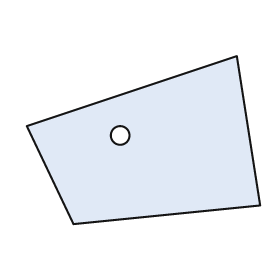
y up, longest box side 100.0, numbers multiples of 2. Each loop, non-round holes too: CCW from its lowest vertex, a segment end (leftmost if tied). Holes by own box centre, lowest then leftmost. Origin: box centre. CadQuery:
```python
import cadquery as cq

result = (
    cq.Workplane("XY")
    .moveTo(-30.0, -36.0)
    .lineTo(50.0, -28.0)
    .lineTo(40.0, 36.0)
    .lineTo(-50.0, 6.0)
    .close()
    .moveTo(-10.0, 2.0)
    .circle(4.0)
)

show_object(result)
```